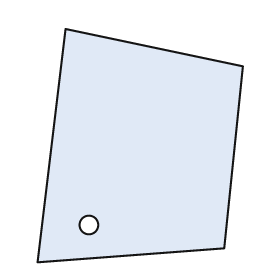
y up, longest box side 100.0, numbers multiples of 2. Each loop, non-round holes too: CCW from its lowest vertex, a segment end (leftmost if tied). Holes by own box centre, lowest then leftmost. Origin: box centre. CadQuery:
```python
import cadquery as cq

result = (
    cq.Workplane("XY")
    .moveTo(-44.0, -50.0)
    .lineTo(36.0, -44.0)
    .lineTo(44.0, 34.0)
    .lineTo(-32.0, 50.0)
    .close()
    .moveTo(-22.0, -34.0)
    .circle(4.0)
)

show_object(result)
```